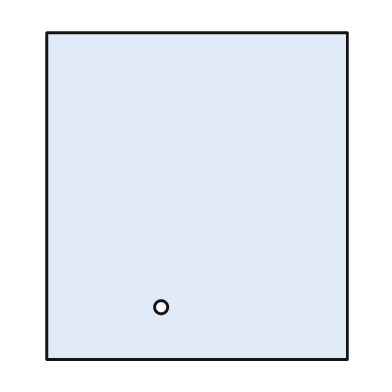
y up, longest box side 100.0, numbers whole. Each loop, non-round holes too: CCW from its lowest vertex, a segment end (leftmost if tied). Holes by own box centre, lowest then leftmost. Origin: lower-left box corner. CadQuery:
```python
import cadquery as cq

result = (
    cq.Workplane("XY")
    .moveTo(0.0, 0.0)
    .lineTo(92.0, 0.0)
    .lineTo(92.0, 100.0)
    .lineTo(0.0, 100.0)
    .close()
    .moveTo(35.0, 16.0)
    .circle(2.0)
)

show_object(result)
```